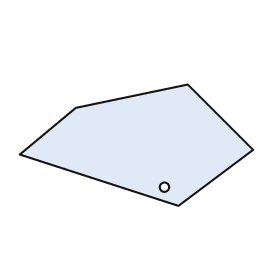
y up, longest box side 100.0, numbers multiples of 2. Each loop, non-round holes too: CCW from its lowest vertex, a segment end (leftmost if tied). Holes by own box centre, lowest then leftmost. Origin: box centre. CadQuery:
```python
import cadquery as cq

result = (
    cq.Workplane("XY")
    .moveTo(18.0, -26.0)
    .lineTo(50.0, -2.0)
    .lineTo(22.0, 26.0)
    .lineTo(-26.0, 16.0)
    .lineTo(-50.0, -4.0)
    .close()
    .moveTo(12.0, -18.0)
    .circle(2.0)
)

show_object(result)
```